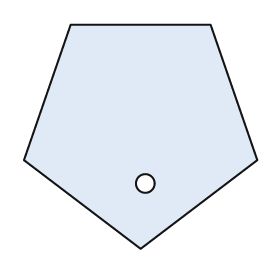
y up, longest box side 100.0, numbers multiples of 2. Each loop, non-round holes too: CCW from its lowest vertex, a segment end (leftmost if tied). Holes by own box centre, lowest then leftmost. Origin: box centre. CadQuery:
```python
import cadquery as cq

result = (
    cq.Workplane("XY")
    .moveTo(0.0, -48.0)
    .lineTo(50.0, -10.0)
    .lineTo(30.0, 48.0)
    .lineTo(-30.0, 48.0)
    .lineTo(-50.0, -10.0)
    .close()
    .moveTo(2.0, -20.0)
    .circle(4.0)
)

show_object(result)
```